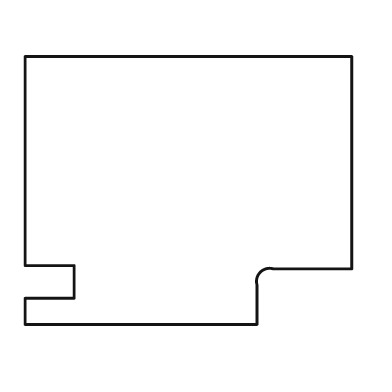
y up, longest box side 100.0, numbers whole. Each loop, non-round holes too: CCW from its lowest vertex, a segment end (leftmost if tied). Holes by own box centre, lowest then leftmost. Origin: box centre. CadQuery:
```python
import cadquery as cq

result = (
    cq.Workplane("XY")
    .moveTo(-50.0, -41.0)
    .lineTo(21.0, -41.0)
    .lineTo(21.0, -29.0)
    .threePointArc((22.0, -25.0), (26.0, -24.0))
    .lineTo(50.0, -24.0)
    .lineTo(50.0, 41.0)
    .lineTo(-50.0, 41.0)
    .lineTo(-50.0, -23.0)
    .lineTo(-35.0, -23.0)
    .lineTo(-35.0, -33.0)
    .lineTo(-50.0, -33.0)
    .close()
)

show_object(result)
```